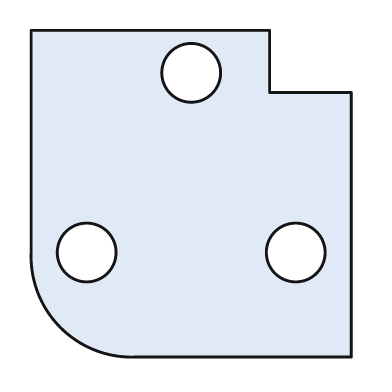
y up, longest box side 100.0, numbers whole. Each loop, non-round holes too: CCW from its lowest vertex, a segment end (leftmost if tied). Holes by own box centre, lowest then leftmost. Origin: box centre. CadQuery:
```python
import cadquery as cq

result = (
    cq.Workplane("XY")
    .moveTo(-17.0, -50.0)
    .lineTo(49.0, -50.0)
    .lineTo(49.0, 31.0)
    .lineTo(24.0, 31.0)
    .lineTo(24.0, 50.0)
    .lineTo(-49.0, 50.0)
    .lineTo(-49.0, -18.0)
    .threePointArc((-40.0, -41.0), (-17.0, -50.0))
    .close()
    .moveTo(-32.0, -18.0)
    .circle(9.0)
    .moveTo(32.0, -18.0)
    .circle(9.0)
    .moveTo(0.0, 37.0)
    .circle(9.0)
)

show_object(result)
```